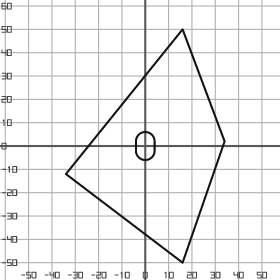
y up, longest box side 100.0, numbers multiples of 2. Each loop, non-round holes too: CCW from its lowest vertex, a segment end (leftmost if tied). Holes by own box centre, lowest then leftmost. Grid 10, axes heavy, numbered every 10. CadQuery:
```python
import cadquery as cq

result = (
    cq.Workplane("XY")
    .moveTo(16.0, -50.0)
    .lineTo(34.0, 2.0)
    .lineTo(16.0, 50.0)
    .lineTo(-34.0, -12.0)
    .close()
    .moveTo(-4.0, -2.0)
    .threePointArc((0.0, -6.0), (4.0, -2.0))
    .lineTo(4.0, 2.0)
    .threePointArc((0.0, 6.0), (-4.0, 2.0))
    .close()
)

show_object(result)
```